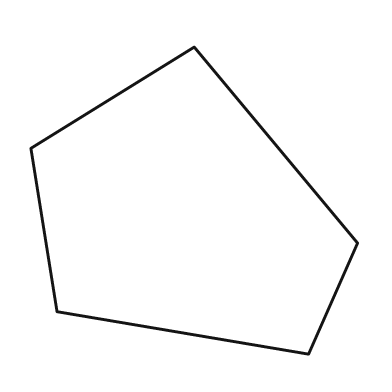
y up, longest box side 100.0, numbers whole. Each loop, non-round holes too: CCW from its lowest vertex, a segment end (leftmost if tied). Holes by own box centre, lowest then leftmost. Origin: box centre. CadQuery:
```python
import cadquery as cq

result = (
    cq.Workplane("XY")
    .moveTo(35.0, -47.0)
    .lineTo(50.0, -13.0)
    .lineTo(0.0, 47.0)
    .lineTo(-50.0, 16.0)
    .lineTo(-42.0, -34.0)
    .close()
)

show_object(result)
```